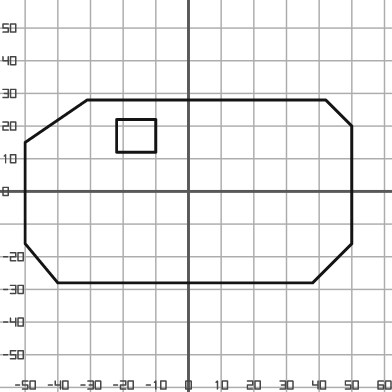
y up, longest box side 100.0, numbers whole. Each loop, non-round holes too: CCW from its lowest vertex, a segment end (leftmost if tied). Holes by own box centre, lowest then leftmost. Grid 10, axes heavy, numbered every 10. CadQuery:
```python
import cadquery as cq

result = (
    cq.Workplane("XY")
    .moveTo(-40.0, -28.0)
    .lineTo(38.0, -28.0)
    .lineTo(50.0, -16.0)
    .lineTo(50.0, 20.0)
    .lineTo(42.0, 28.0)
    .lineTo(-31.0, 28.0)
    .lineTo(-50.0, 15.0)
    .lineTo(-50.0, -16.0)
    .close()
    .moveTo(-22.0, 12.0)
    .lineTo(-10.0, 12.0)
    .lineTo(-10.0, 22.0)
    .lineTo(-22.0, 22.0)
    .close()
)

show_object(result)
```